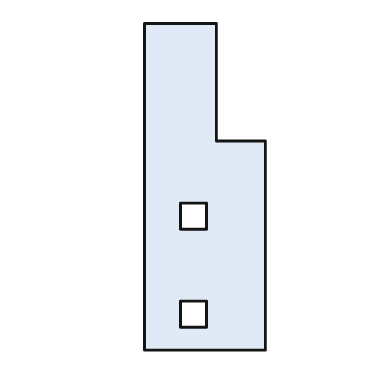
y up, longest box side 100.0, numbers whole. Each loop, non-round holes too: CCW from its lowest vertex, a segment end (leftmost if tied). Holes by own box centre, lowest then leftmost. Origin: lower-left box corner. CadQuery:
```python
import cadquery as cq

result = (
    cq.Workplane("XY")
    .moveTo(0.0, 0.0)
    .lineTo(37.0, 0.0)
    .lineTo(37.0, 64.0)
    .lineTo(22.0, 64.0)
    .lineTo(22.0, 100.0)
    .lineTo(0.0, 100.0)
    .close()
    .moveTo(11.0, 7.0)
    .lineTo(19.0, 7.0)
    .lineTo(19.0, 15.0)
    .lineTo(11.0, 15.0)
    .close()
    .moveTo(11.0, 37.0)
    .lineTo(19.0, 37.0)
    .lineTo(19.0, 45.0)
    .lineTo(11.0, 45.0)
    .close()
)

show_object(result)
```